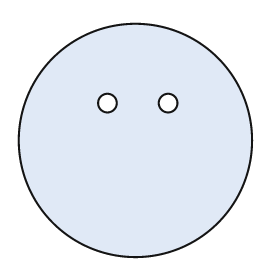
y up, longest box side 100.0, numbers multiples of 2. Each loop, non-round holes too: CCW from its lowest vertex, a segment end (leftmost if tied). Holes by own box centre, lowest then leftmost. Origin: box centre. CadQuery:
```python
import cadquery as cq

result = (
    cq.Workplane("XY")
    .moveTo(0.0, 0.0)
    .circle(50.0)
    .moveTo(-12.0, 16.0)
    .circle(4.0)
    .moveTo(14.0, 16.0)
    .circle(4.0)
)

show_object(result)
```